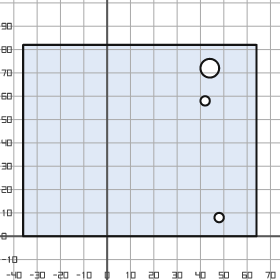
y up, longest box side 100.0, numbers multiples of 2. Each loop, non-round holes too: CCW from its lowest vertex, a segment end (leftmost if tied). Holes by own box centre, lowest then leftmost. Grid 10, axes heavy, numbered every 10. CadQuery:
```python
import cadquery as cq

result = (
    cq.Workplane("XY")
    .moveTo(-36.0, 0.0)
    .lineTo(64.0, 0.0)
    .lineTo(64.0, 82.0)
    .lineTo(-36.0, 82.0)
    .close()
    .moveTo(48.0, 8.0)
    .circle(2.0)
    .moveTo(42.0, 58.0)
    .circle(2.0)
    .moveTo(44.0, 72.0)
    .circle(4.0)
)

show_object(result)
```